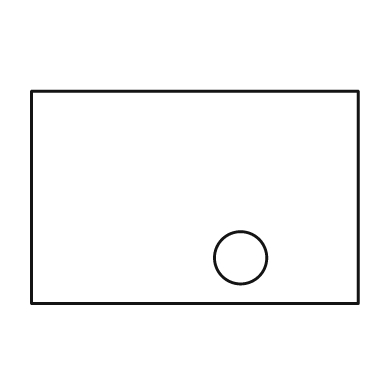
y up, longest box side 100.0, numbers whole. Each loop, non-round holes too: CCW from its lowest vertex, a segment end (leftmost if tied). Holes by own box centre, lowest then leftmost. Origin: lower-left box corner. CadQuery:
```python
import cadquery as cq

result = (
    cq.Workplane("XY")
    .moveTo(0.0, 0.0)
    .lineTo(100.0, 0.0)
    .lineTo(100.0, 65.0)
    .lineTo(0.0, 65.0)
    .close()
    .moveTo(64.0, 14.0)
    .circle(8.0)
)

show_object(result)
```